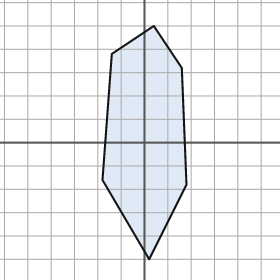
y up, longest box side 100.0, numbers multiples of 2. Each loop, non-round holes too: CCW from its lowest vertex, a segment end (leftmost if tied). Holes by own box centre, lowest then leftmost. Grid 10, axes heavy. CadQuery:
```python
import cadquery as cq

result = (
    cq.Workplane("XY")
    .moveTo(2.0, -50.0)
    .lineTo(18.0, -18.0)
    .lineTo(16.0, 32.0)
    .lineTo(4.0, 50.0)
    .lineTo(-14.0, 38.0)
    .lineTo(-18.0, -16.0)
    .close()
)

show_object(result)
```